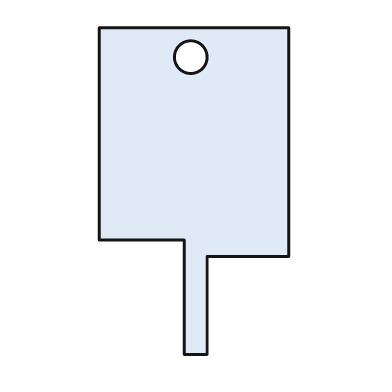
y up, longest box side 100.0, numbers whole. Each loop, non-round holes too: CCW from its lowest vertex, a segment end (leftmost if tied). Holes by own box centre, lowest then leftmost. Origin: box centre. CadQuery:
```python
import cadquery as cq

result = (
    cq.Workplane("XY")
    .moveTo(-3.0, -50.0)
    .lineTo(4.0, -50.0)
    .lineTo(4.0, -20.0)
    .lineTo(29.0, -20.0)
    .lineTo(29.0, 50.0)
    .lineTo(-29.0, 50.0)
    .lineTo(-29.0, -15.0)
    .lineTo(-3.0, -15.0)
    .close()
    .moveTo(-1.0, 41.0)
    .circle(5.0)
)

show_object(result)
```